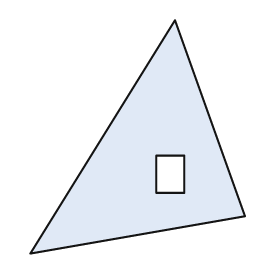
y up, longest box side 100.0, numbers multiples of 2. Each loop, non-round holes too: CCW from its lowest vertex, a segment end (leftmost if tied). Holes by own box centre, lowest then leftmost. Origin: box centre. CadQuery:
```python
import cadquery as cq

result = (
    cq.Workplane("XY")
    .moveTo(-46.0, -50.0)
    .lineTo(46.0, -34.0)
    .lineTo(16.0, 50.0)
    .close()
    .moveTo(8.0, -24.0)
    .lineTo(20.0, -24.0)
    .lineTo(20.0, -8.0)
    .lineTo(8.0, -8.0)
    .close()
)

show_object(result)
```